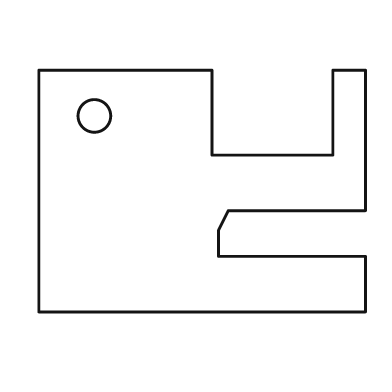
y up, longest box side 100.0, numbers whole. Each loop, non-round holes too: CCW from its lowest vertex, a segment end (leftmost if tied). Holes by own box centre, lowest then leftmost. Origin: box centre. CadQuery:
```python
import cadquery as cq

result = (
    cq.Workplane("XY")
    .moveTo(-50.0, -37.0)
    .lineTo(50.0, -37.0)
    .lineTo(50.0, -20.0)
    .lineTo(5.0, -20.0)
    .lineTo(5.0, -12.0)
    .lineTo(8.0, -6.0)
    .lineTo(50.0, -6.0)
    .lineTo(50.0, 37.0)
    .lineTo(40.0, 37.0)
    .lineTo(40.0, 11.0)
    .lineTo(3.0, 11.0)
    .lineTo(3.0, 37.0)
    .lineTo(-50.0, 37.0)
    .close()
    .moveTo(-33.0, 23.0)
    .circle(5.0)
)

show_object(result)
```